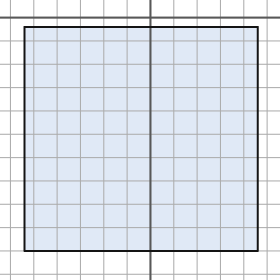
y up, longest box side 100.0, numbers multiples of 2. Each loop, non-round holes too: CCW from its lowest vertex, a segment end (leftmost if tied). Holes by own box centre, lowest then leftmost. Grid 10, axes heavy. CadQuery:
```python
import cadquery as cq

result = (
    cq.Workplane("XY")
    .moveTo(-54.0, -100.0)
    .lineTo(46.0, -100.0)
    .lineTo(46.0, -4.0)
    .lineTo(-54.0, -4.0)
    .close()
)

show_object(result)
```